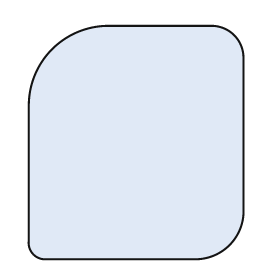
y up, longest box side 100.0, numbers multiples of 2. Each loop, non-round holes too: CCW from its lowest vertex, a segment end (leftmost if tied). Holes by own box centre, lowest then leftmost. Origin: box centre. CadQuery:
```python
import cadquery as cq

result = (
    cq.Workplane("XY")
    .moveTo(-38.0, -50.0)
    .lineTo(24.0, -50.0)
    .threePointArc((40.0, -44.0), (46.0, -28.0))
    .lineTo(46.0, 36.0)
    .threePointArc((42.0, 46.0), (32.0, 50.0))
    .lineTo(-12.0, 50.0)
    .threePointArc((-36.0, 40.0), (-46.0, 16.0))
    .lineTo(-46.0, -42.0)
    .threePointArc((-44.0, -48.0), (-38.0, -50.0))
    .close()
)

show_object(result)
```